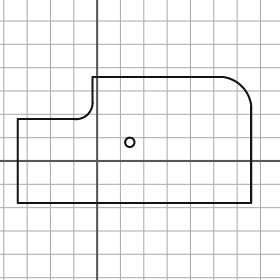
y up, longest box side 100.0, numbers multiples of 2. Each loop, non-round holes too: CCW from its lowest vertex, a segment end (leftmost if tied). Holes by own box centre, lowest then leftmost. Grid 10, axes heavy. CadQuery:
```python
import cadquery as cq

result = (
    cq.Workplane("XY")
    .moveTo(-34.0, -18.0)
    .lineTo(66.0, -18.0)
    .lineTo(66.0, 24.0)
    .threePointArc((62.0, 32.0), (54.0, 36.0))
    .lineTo(-2.0, 36.0)
    .lineTo(-2.0, 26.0)
    .threePointArc((-4.0, 20.0), (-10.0, 18.0))
    .lineTo(-34.0, 18.0)
    .close()
    .moveTo(14.0, 8.0)
    .circle(2.0)
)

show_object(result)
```